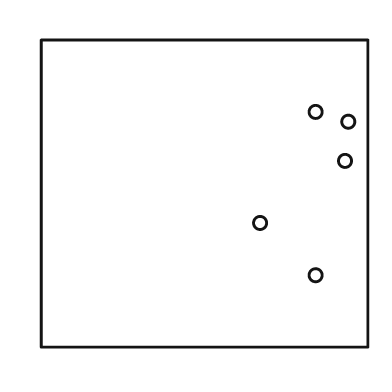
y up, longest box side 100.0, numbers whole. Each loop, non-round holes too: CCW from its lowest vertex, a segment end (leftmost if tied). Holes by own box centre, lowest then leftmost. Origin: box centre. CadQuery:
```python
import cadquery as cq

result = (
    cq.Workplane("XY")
    .moveTo(-50.0, -47.0)
    .lineTo(50.0, -47.0)
    .lineTo(50.0, 47.0)
    .lineTo(-50.0, 47.0)
    .close()
    .moveTo(34.0, -25.0)
    .circle(2.0)
    .moveTo(17.0, -9.0)
    .circle(2.0)
    .moveTo(43.0, 10.0)
    .circle(2.0)
    .moveTo(44.0, 22.0)
    .circle(2.0)
    .moveTo(34.0, 25.0)
    .circle(2.0)
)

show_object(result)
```